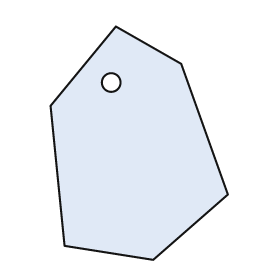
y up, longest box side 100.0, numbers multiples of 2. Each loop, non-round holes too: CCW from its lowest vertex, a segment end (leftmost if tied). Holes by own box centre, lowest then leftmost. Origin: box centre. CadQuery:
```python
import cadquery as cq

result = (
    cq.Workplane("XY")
    .moveTo(6.0, -50.0)
    .lineTo(38.0, -22.0)
    .lineTo(18.0, 34.0)
    .lineTo(-10.0, 50.0)
    .lineTo(-38.0, 16.0)
    .lineTo(-32.0, -44.0)
    .close()
    .moveTo(-12.0, 26.0)
    .circle(4.0)
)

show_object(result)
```